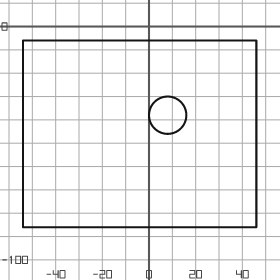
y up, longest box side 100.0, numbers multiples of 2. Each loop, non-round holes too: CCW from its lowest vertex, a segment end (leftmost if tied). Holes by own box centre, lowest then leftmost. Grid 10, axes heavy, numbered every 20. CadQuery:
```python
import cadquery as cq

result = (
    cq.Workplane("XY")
    .moveTo(-54.0, -86.0)
    .lineTo(46.0, -86.0)
    .lineTo(46.0, -6.0)
    .lineTo(-54.0, -6.0)
    .close()
    .moveTo(8.0, -38.0)
    .circle(8.0)
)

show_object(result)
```